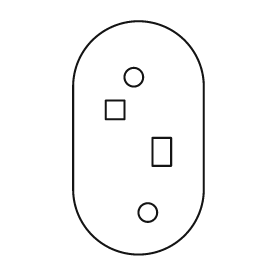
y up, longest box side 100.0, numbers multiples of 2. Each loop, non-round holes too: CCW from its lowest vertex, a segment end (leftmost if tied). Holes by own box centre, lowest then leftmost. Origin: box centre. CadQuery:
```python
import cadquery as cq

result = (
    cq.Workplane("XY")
    .moveTo(-28.0, -22.0)
    .threePointArc((0.0, -50.0), (28.0, -22.0))
    .lineTo(28.0, 22.0)
    .threePointArc((0.0, 50.0), (-28.0, 22.0))
    .close()
    .moveTo(4.0, -32.0)
    .circle(4.0)
    .moveTo(6.0, -12.0)
    .lineTo(14.0, -12.0)
    .lineTo(14.0, 0.0)
    .lineTo(6.0, 0.0)
    .close()
    .moveTo(-14.0, 8.0)
    .lineTo(-6.0, 8.0)
    .lineTo(-6.0, 16.0)
    .lineTo(-14.0, 16.0)
    .close()
    .moveTo(-2.0, 26.0)
    .circle(4.0)
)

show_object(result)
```